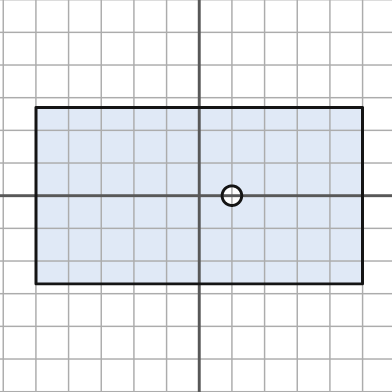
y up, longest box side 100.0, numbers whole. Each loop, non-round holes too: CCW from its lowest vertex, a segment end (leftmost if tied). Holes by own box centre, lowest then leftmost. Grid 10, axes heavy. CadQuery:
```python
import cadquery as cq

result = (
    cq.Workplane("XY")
    .moveTo(-50.0, -27.0)
    .lineTo(50.0, -27.0)
    .lineTo(50.0, 27.0)
    .lineTo(-50.0, 27.0)
    .close()
    .moveTo(10.0, 0.0)
    .circle(3.0)
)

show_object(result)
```